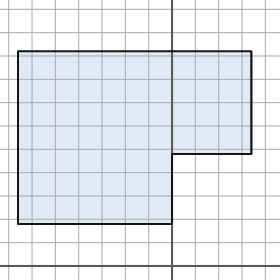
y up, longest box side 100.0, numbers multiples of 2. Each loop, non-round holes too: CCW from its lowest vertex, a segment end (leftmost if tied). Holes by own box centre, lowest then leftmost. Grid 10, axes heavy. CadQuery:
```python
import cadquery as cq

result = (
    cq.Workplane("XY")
    .moveTo(-66.0, 18.0)
    .lineTo(0.0, 18.0)
    .lineTo(0.0, 48.0)
    .lineTo(34.0, 48.0)
    .lineTo(34.0, 92.0)
    .lineTo(-66.0, 92.0)
    .close()
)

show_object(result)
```